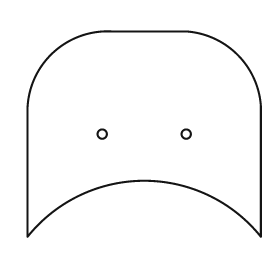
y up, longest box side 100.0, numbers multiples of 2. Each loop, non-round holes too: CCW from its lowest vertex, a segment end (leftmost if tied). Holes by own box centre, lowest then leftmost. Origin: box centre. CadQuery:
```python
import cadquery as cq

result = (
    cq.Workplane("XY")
    .moveTo(-50.0, -44.0)
    .threePointArc((0.0, -20.0), (50.0, -44.0))
    .lineTo(50.0, 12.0)
    .threePointArc((40.0, 34.0), (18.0, 44.0))
    .lineTo(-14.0, 44.0)
    .threePointArc((-40.0, 34.0), (-50.0, 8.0))
    .close()
    .moveTo(-18.0, 0.0)
    .circle(2.0)
    .moveTo(18.0, 0.0)
    .circle(2.0)
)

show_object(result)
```